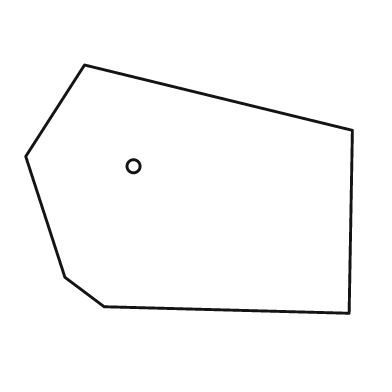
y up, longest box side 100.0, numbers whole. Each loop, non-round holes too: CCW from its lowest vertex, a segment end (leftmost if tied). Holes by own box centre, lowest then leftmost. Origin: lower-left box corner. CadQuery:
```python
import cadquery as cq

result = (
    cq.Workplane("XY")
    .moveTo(99.0, 0.0)
    .lineTo(100.0, 56.0)
    .lineTo(18.0, 76.0)
    .lineTo(0.0, 48.0)
    .lineTo(12.0, 11.0)
    .lineTo(24.0, 2.0)
    .close()
    .moveTo(33.0, 45.0)
    .circle(2.0)
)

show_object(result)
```